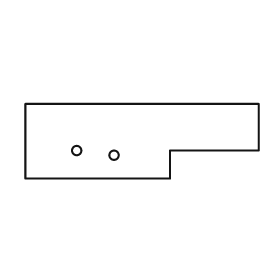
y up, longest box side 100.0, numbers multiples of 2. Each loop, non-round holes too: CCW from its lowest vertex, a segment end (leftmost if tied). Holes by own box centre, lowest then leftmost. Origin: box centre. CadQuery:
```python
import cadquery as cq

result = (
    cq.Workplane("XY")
    .moveTo(-50.0, -16.0)
    .lineTo(12.0, -16.0)
    .lineTo(12.0, -4.0)
    .lineTo(50.0, -4.0)
    .lineTo(50.0, 16.0)
    .lineTo(-50.0, 16.0)
    .close()
    .moveTo(-12.0, -6.0)
    .circle(2.0)
    .moveTo(-28.0, -4.0)
    .circle(2.0)
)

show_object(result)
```